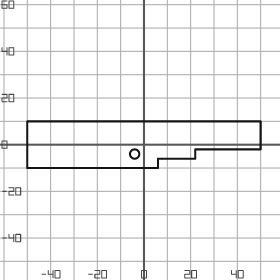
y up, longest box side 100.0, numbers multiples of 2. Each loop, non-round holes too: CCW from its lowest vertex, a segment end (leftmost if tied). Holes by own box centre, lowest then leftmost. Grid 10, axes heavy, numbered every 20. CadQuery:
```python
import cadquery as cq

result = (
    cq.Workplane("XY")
    .moveTo(-50.0, -10.0)
    .lineTo(6.0, -10.0)
    .lineTo(6.0, -6.0)
    .lineTo(22.0, -6.0)
    .lineTo(22.0, -2.0)
    .lineTo(50.0, -2.0)
    .lineTo(50.0, 10.0)
    .lineTo(-50.0, 10.0)
    .close()
    .moveTo(-4.0, -4.0)
    .circle(2.0)
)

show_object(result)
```